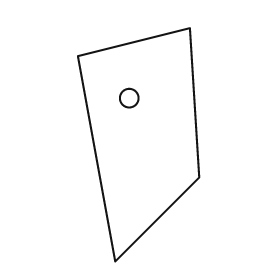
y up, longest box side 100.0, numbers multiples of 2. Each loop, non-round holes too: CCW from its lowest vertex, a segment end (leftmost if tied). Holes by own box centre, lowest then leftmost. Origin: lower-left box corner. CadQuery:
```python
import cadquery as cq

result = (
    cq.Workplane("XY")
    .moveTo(16.0, 0.0)
    .lineTo(52.0, 36.0)
    .lineTo(48.0, 100.0)
    .lineTo(0.0, 88.0)
    .close()
    .moveTo(22.0, 70.0)
    .circle(4.0)
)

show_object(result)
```